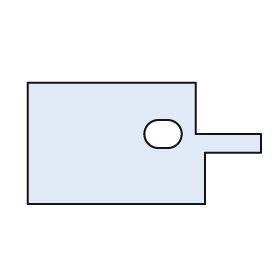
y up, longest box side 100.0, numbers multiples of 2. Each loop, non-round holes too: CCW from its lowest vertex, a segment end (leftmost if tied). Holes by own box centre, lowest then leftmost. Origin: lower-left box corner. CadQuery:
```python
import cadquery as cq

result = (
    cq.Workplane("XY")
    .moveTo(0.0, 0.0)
    .lineTo(76.0, 0.0)
    .lineTo(76.0, 22.0)
    .lineTo(100.0, 22.0)
    .lineTo(100.0, 30.0)
    .lineTo(72.0, 30.0)
    .lineTo(72.0, 52.0)
    .lineTo(0.0, 52.0)
    .close()
    .moveTo(56.0, 24.0)
    .lineTo(60.0, 24.0)
    .threePointArc((66.0, 30.0), (60.0, 36.0))
    .lineTo(56.0, 36.0)
    .threePointArc((50.0, 30.0), (56.0, 24.0))
    .close()
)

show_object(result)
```